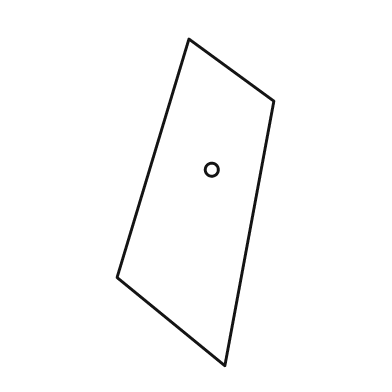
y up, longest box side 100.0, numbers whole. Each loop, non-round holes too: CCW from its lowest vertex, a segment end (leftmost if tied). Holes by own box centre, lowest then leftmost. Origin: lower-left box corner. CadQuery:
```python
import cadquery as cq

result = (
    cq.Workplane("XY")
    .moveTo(33.0, 0.0)
    .lineTo(48.0, 81.0)
    .lineTo(22.0, 100.0)
    .lineTo(0.0, 27.0)
    .close()
    .moveTo(29.0, 60.0)
    .circle(2.0)
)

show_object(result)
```